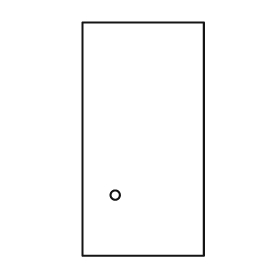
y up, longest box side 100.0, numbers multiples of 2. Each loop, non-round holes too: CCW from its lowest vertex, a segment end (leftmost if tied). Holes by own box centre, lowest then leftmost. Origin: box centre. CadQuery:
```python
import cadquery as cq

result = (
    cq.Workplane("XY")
    .moveTo(-26.0, -50.0)
    .lineTo(26.0, -50.0)
    .lineTo(26.0, 50.0)
    .lineTo(-26.0, 50.0)
    .close()
    .moveTo(-12.0, -24.0)
    .circle(2.0)
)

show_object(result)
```